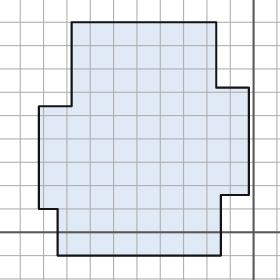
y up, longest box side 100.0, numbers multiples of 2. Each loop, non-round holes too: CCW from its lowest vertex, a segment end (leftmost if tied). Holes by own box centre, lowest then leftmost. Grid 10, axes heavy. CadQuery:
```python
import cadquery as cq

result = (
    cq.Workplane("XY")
    .moveTo(-84.0, -10.0)
    .lineTo(-14.0, -10.0)
    .lineTo(-14.0, 16.0)
    .lineTo(-2.0, 16.0)
    .lineTo(-2.0, 62.0)
    .lineTo(-16.0, 62.0)
    .lineTo(-16.0, 90.0)
    .lineTo(-78.0, 90.0)
    .lineTo(-78.0, 54.0)
    .lineTo(-92.0, 54.0)
    .lineTo(-92.0, 10.0)
    .lineTo(-84.0, 10.0)
    .close()
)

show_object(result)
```